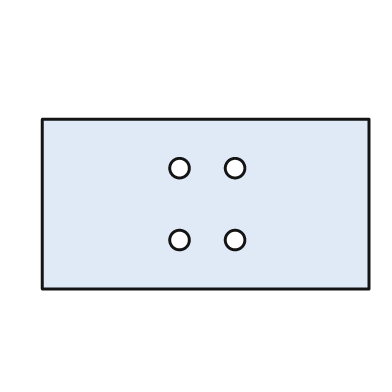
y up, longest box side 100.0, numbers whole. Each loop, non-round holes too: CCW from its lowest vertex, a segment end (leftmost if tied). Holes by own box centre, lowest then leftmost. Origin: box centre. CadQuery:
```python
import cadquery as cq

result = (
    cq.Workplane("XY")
    .moveTo(-50.0, -26.0)
    .lineTo(50.0, -26.0)
    .lineTo(50.0, 26.0)
    .lineTo(-50.0, 26.0)
    .close()
    .moveTo(-8.0, -11.0)
    .circle(3.0)
    .moveTo(9.0, -11.0)
    .circle(3.0)
    .moveTo(-8.0, 11.0)
    .circle(3.0)
    .moveTo(9.0, 11.0)
    .circle(3.0)
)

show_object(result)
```